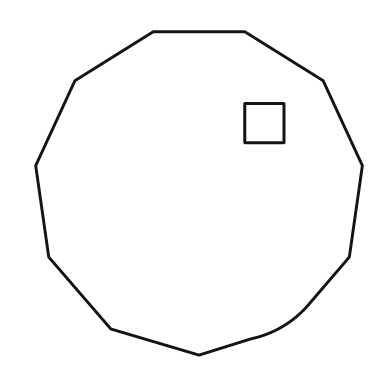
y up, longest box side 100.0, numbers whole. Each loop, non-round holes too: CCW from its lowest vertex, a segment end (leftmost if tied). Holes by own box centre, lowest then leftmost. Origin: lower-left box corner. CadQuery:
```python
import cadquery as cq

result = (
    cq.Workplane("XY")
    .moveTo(50.0, 0.0)
    .lineTo(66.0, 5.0)
    .threePointArc((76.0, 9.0), (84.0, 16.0))
    .lineTo(96.0, 30.0)
    .lineTo(100.0, 58.0)
    .lineTo(88.0, 84.0)
    .lineTo(64.0, 99.0)
    .lineTo(36.0, 99.0)
    .lineTo(12.0, 84.0)
    .lineTo(0.0, 58.0)
    .lineTo(4.0, 30.0)
    .lineTo(23.0, 8.0)
    .close()
    .moveTo(64.0, 65.0)
    .lineTo(76.0, 65.0)
    .lineTo(76.0, 77.0)
    .lineTo(64.0, 77.0)
    .close()
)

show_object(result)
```